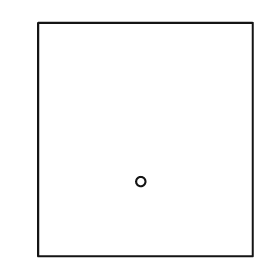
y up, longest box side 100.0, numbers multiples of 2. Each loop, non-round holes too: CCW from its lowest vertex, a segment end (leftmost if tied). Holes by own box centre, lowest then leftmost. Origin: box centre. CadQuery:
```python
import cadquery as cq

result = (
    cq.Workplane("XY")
    .moveTo(-46.0, -50.0)
    .lineTo(46.0, -50.0)
    .lineTo(46.0, 50.0)
    .lineTo(-46.0, 50.0)
    .close()
    .moveTo(-2.0, -18.0)
    .circle(2.0)
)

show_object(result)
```